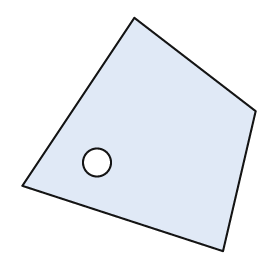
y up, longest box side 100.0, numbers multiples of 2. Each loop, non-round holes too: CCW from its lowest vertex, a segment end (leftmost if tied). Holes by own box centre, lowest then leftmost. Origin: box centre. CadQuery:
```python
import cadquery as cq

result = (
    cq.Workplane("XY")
    .moveTo(36.0, -50.0)
    .lineTo(50.0, 10.0)
    .lineTo(-2.0, 50.0)
    .lineTo(-50.0, -22.0)
    .close()
    .moveTo(-18.0, -12.0)
    .circle(6.0)
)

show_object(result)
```